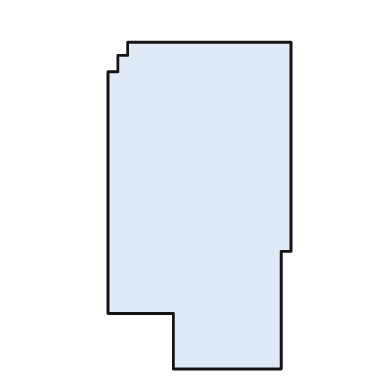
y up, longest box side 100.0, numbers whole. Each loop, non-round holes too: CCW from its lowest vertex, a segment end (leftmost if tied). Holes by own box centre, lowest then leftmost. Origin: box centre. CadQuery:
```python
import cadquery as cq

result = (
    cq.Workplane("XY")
    .moveTo(-8.0, -50.0)
    .lineTo(25.0, -50.0)
    .lineTo(25.0, -14.0)
    .lineTo(28.0, -14.0)
    .lineTo(28.0, 50.0)
    .lineTo(-22.0, 50.0)
    .lineTo(-22.0, 46.0)
    .lineTo(-25.0, 46.0)
    .lineTo(-25.0, 41.0)
    .lineTo(-28.0, 41.0)
    .lineTo(-28.0, -33.0)
    .lineTo(-8.0, -33.0)
    .close()
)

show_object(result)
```